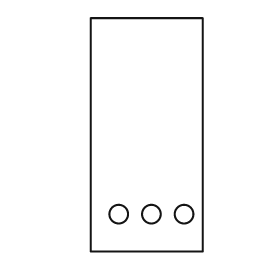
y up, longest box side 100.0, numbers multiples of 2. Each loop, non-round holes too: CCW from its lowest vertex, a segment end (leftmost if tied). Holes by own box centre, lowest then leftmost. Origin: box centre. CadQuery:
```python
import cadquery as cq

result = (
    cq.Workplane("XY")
    .moveTo(-24.0, -50.0)
    .lineTo(24.0, -50.0)
    .lineTo(24.0, 50.0)
    .lineTo(-24.0, 50.0)
    .close()
    .moveTo(-12.0, -34.0)
    .circle(4.0)
    .moveTo(2.0, -34.0)
    .circle(4.0)
    .moveTo(16.0, -34.0)
    .circle(4.0)
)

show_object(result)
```